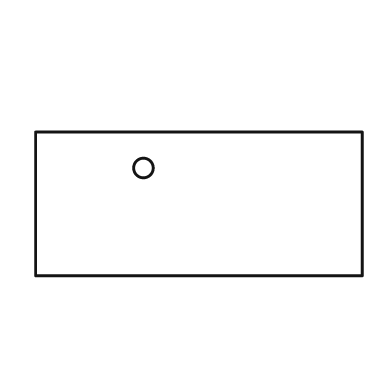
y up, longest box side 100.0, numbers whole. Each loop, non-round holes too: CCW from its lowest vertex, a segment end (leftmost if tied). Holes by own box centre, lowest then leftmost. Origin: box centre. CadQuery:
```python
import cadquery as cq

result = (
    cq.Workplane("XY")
    .moveTo(-50.0, -22.0)
    .lineTo(50.0, -22.0)
    .lineTo(50.0, 22.0)
    .lineTo(-50.0, 22.0)
    .close()
    .moveTo(-17.0, 11.0)
    .circle(3.0)
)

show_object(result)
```